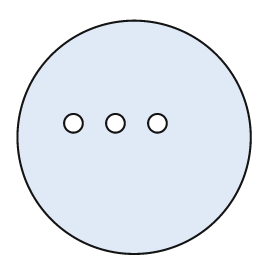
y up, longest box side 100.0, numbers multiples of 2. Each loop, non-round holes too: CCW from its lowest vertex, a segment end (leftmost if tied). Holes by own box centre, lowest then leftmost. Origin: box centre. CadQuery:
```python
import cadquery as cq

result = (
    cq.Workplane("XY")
    .moveTo(0.0, 0.0)
    .circle(50.0)
    .moveTo(-26.0, 6.0)
    .circle(4.0)
    .moveTo(-8.0, 6.0)
    .circle(4.0)
    .moveTo(10.0, 6.0)
    .circle(4.0)
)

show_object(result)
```